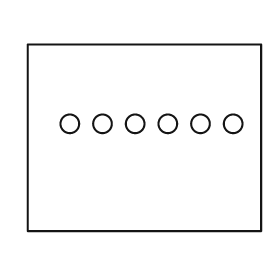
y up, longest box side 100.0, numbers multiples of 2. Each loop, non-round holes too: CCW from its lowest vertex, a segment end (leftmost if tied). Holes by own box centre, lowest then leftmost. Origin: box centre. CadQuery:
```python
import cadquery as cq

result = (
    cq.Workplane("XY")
    .moveTo(-50.0, -40.0)
    .lineTo(50.0, -40.0)
    .lineTo(50.0, 40.0)
    .lineTo(-50.0, 40.0)
    .close()
    .moveTo(-32.0, 6.0)
    .circle(4.0)
    .moveTo(-18.0, 6.0)
    .circle(4.0)
    .moveTo(-4.0, 6.0)
    .circle(4.0)
    .moveTo(10.0, 6.0)
    .circle(4.0)
    .moveTo(24.0, 6.0)
    .circle(4.0)
    .moveTo(38.0, 6.0)
    .circle(4.0)
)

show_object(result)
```